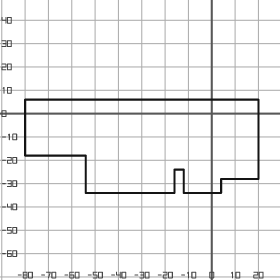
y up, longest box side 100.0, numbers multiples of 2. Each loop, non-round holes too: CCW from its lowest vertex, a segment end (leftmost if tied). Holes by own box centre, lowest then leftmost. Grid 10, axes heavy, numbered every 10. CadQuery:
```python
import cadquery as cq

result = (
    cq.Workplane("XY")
    .moveTo(-54.0, -34.0)
    .lineTo(-16.0, -34.0)
    .lineTo(-16.0, -24.0)
    .lineTo(-12.0, -24.0)
    .lineTo(-12.0, -34.0)
    .lineTo(4.0, -34.0)
    .lineTo(4.0, -28.0)
    .lineTo(20.0, -28.0)
    .lineTo(20.0, 6.0)
    .lineTo(-80.0, 6.0)
    .lineTo(-80.0, -18.0)
    .lineTo(-54.0, -18.0)
    .close()
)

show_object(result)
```